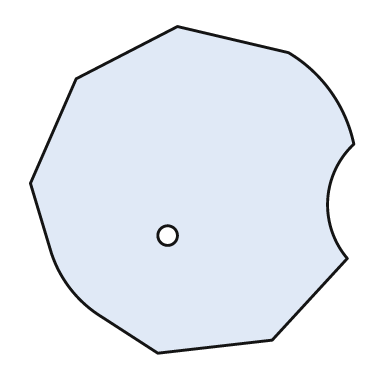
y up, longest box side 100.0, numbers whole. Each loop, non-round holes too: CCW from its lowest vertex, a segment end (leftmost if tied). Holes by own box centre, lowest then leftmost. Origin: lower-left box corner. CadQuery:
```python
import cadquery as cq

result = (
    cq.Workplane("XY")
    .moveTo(39.0, 0.0)
    .lineTo(74.0, 4.0)
    .lineTo(97.0, 29.0)
    .threePointArc((91.0, 47.0), (99.0, 64.0))
    .threePointArc((92.0, 80.0), (79.0, 92.0))
    .lineTo(45.0, 100.0)
    .lineTo(14.0, 84.0)
    .lineTo(0.0, 52.0)
    .lineTo(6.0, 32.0)
    .threePointArc((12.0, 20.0), (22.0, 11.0))
    .close()
    .moveTo(42.0, 36.0)
    .circle(3.0)
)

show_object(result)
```